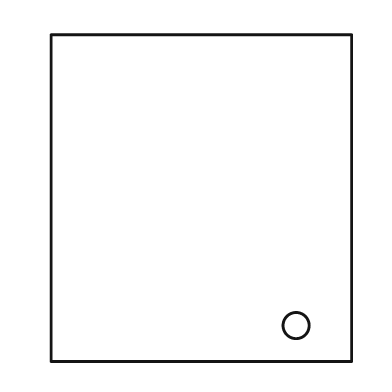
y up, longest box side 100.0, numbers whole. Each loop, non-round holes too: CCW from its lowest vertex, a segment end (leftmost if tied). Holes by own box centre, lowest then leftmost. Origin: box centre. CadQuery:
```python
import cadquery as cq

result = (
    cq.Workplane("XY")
    .moveTo(-46.0, -50.0)
    .lineTo(46.0, -50.0)
    .lineTo(46.0, 50.0)
    .lineTo(-46.0, 50.0)
    .close()
    .moveTo(29.0, -39.0)
    .circle(4.0)
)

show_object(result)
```